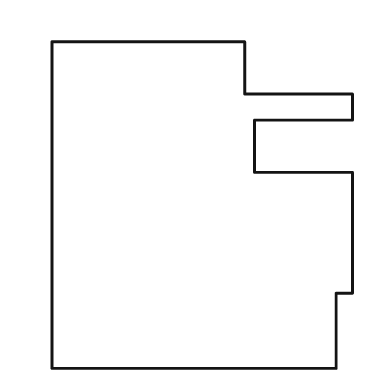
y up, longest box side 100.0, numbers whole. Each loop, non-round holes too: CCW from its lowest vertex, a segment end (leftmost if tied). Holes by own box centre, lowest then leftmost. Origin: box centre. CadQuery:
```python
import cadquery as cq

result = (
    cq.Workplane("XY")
    .moveTo(-46.0, -50.0)
    .lineTo(41.0, -50.0)
    .lineTo(41.0, -27.0)
    .lineTo(46.0, -27.0)
    .lineTo(46.0, 10.0)
    .lineTo(16.0, 10.0)
    .lineTo(16.0, 26.0)
    .lineTo(46.0, 26.0)
    .lineTo(46.0, 34.0)
    .lineTo(13.0, 34.0)
    .lineTo(13.0, 50.0)
    .lineTo(-46.0, 50.0)
    .close()
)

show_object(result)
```